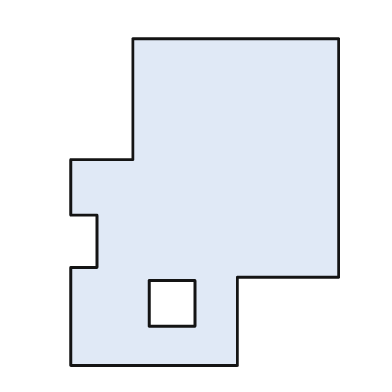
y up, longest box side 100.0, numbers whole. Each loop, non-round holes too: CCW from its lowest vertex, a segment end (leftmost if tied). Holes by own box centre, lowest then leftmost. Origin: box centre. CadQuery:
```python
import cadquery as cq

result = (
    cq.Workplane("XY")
    .moveTo(-41.0, -50.0)
    .lineTo(10.0, -50.0)
    .lineTo(10.0, -23.0)
    .lineTo(41.0, -23.0)
    .lineTo(41.0, 50.0)
    .lineTo(-22.0, 50.0)
    .lineTo(-22.0, 13.0)
    .lineTo(-41.0, 13.0)
    .lineTo(-41.0, -4.0)
    .lineTo(-33.0, -4.0)
    .lineTo(-33.0, -20.0)
    .lineTo(-41.0, -20.0)
    .close()
    .moveTo(-17.0, -38.0)
    .lineTo(-3.0, -38.0)
    .lineTo(-3.0, -24.0)
    .lineTo(-17.0, -24.0)
    .close()
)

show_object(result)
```